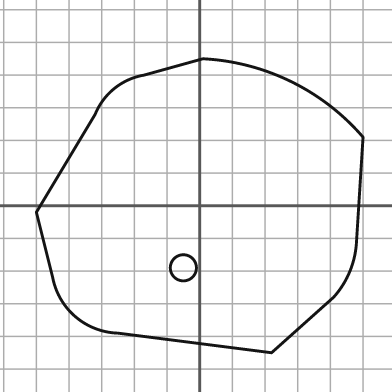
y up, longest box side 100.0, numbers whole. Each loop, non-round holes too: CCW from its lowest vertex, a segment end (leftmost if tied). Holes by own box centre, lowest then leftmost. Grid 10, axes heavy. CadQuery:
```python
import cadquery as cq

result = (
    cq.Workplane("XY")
    .moveTo(22.0, -45.0)
    .lineTo(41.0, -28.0)
    .threePointArc((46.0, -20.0), (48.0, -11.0))
    .lineTo(50.0, 21.0)
    .threePointArc((28.0, 38.0), (1.0, 45.0))
    .lineTo(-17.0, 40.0)
    .threePointArc((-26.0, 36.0), (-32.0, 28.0))
    .lineTo(-50.0, -2.0)
    .lineTo(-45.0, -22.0)
    .threePointArc((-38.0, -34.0), (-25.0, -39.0))
    .close()
    .moveTo(-5.0, -19.0)
    .circle(4.0)
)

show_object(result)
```